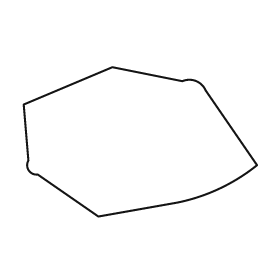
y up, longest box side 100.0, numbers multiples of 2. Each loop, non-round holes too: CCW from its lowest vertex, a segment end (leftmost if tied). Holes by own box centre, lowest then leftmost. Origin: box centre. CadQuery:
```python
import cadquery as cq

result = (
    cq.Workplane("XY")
    .moveTo(-18.0, -32.0)
    .lineTo(16.0, -26.0)
    .threePointArc((34.0, -20.0), (50.0, -10.0))
    .lineTo(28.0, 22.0)
    .threePointArc((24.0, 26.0), (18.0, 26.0))
    .lineTo(-12.0, 32.0)
    .lineTo(-50.0, 16.0)
    .lineTo(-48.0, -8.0)
    .threePointArc((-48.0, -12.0), (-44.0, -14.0))
    .close()
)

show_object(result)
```